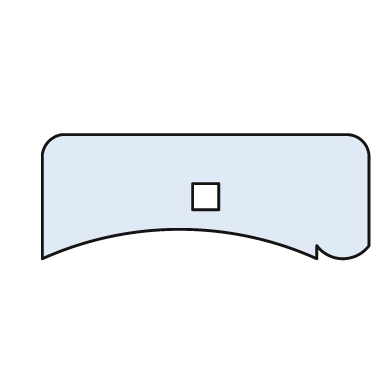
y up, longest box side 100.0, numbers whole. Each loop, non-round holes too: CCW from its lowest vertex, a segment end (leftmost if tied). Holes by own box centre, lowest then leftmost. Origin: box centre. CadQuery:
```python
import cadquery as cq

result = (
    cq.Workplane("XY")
    .moveTo(-50.0, -19.0)
    .threePointArc((-8.0, -10.0), (34.0, -19.0))
    .lineTo(34.0, -15.0)
    .threePointArc((42.0, -19.0), (50.0, -15.0))
    .lineTo(50.0, 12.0)
    .threePointArc((48.0, 17.0), (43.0, 19.0))
    .lineTo(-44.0, 19.0)
    .threePointArc((-48.0, 17.0), (-50.0, 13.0))
    .close()
    .moveTo(-4.0, -4.0)
    .lineTo(4.0, -4.0)
    .lineTo(4.0, 4.0)
    .lineTo(-4.0, 4.0)
    .close()
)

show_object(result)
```